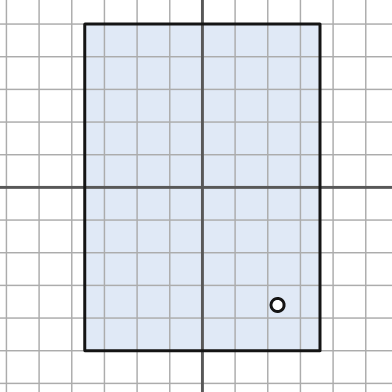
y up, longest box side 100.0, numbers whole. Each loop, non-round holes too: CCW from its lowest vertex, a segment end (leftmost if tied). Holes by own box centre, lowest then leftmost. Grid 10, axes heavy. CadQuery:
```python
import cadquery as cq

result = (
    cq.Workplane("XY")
    .moveTo(-36.0, -50.0)
    .lineTo(36.0, -50.0)
    .lineTo(36.0, 50.0)
    .lineTo(-36.0, 50.0)
    .close()
    .moveTo(23.0, -36.0)
    .circle(2.0)
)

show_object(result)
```